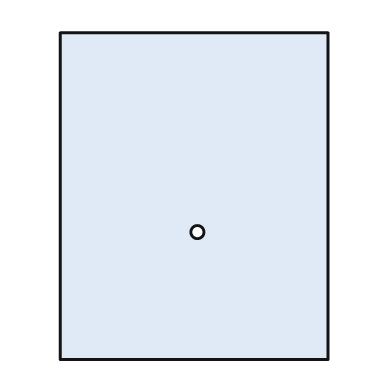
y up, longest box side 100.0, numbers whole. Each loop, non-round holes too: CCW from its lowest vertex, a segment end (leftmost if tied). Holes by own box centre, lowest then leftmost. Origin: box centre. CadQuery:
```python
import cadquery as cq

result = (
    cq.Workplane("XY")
    .moveTo(-41.0, -50.0)
    .lineTo(41.0, -50.0)
    .lineTo(41.0, 50.0)
    .lineTo(-41.0, 50.0)
    .close()
    .moveTo(1.0, -11.0)
    .circle(2.0)
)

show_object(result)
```